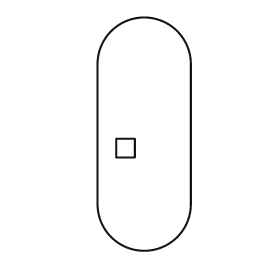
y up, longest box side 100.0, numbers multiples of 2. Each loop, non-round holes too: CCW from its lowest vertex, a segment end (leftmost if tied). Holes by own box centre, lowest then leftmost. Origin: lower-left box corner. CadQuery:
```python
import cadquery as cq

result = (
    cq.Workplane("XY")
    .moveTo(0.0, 20.0)
    .threePointArc((20.0, 0.0), (40.0, 20.0))
    .lineTo(40.0, 80.0)
    .threePointArc((20.0, 100.0), (0.0, 80.0))
    .close()
    .moveTo(8.0, 40.0)
    .lineTo(16.0, 40.0)
    .lineTo(16.0, 48.0)
    .lineTo(8.0, 48.0)
    .close()
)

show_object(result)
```